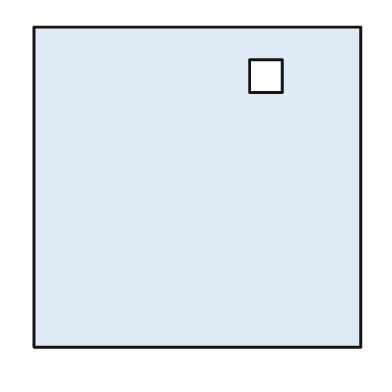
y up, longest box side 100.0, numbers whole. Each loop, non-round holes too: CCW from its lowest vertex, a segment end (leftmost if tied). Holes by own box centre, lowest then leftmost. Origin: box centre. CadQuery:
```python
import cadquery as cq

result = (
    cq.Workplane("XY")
    .moveTo(-50.0, -49.0)
    .lineTo(50.0, -49.0)
    .lineTo(50.0, 49.0)
    .lineTo(-50.0, 49.0)
    .close()
    .moveTo(16.0, 29.0)
    .lineTo(26.0, 29.0)
    .lineTo(26.0, 39.0)
    .lineTo(16.0, 39.0)
    .close()
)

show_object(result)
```